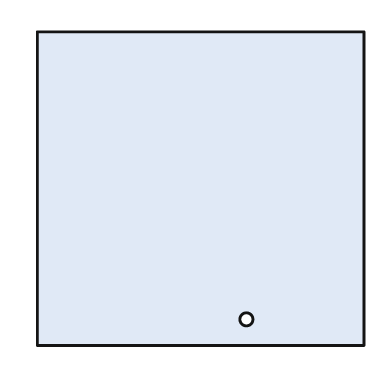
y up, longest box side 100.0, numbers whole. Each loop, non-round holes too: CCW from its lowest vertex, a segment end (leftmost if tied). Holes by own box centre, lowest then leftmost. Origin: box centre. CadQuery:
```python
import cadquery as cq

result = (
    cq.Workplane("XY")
    .moveTo(-50.0, -48.0)
    .lineTo(50.0, -48.0)
    .lineTo(50.0, 48.0)
    .lineTo(-50.0, 48.0)
    .close()
    .moveTo(14.0, -40.0)
    .circle(2.0)
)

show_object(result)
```